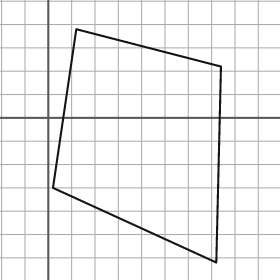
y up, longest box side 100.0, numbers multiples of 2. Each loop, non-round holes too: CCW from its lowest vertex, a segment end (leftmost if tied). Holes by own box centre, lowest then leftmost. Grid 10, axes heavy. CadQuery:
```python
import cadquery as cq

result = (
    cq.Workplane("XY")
    .moveTo(72.0, -62.0)
    .lineTo(74.0, 22.0)
    .lineTo(12.0, 38.0)
    .lineTo(2.0, -30.0)
    .close()
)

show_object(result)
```